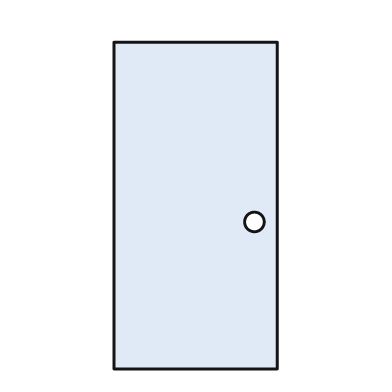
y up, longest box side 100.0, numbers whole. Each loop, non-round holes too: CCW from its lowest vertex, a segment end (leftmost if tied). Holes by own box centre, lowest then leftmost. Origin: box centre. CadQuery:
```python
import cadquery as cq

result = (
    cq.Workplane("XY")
    .moveTo(-25.0, -50.0)
    .lineTo(25.0, -50.0)
    .lineTo(25.0, 50.0)
    .lineTo(-25.0, 50.0)
    .close()
    .moveTo(18.0, -5.0)
    .circle(3.0)
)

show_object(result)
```